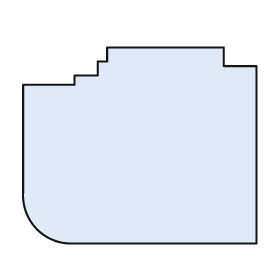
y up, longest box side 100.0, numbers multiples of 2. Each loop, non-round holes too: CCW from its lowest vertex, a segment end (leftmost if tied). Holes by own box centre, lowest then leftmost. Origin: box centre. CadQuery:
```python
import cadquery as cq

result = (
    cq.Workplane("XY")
    .moveTo(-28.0, -42.0)
    .lineTo(50.0, -42.0)
    .lineTo(50.0, 34.0)
    .lineTo(36.0, 34.0)
    .lineTo(36.0, 42.0)
    .lineTo(-14.0, 42.0)
    .lineTo(-14.0, 36.0)
    .lineTo(-18.0, 36.0)
    .lineTo(-18.0, 30.0)
    .lineTo(-28.0, 30.0)
    .lineTo(-28.0, 26.0)
    .lineTo(-50.0, 26.0)
    .lineTo(-50.0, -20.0)
    .threePointArc((-44.0, -36.0), (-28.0, -42.0))
    .close()
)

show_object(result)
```